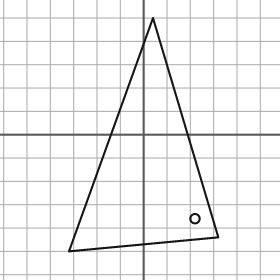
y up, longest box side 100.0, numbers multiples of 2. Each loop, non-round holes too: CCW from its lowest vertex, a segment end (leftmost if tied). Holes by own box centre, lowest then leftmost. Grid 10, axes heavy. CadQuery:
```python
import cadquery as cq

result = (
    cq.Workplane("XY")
    .moveTo(-32.0, -50.0)
    .lineTo(32.0, -44.0)
    .lineTo(4.0, 50.0)
    .close()
    .moveTo(22.0, -36.0)
    .circle(2.0)
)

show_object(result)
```